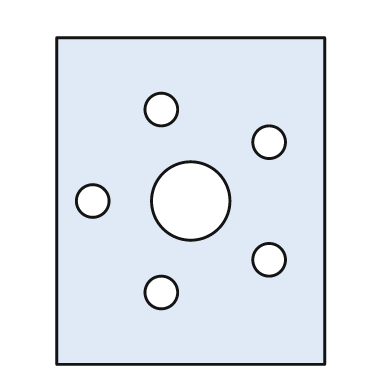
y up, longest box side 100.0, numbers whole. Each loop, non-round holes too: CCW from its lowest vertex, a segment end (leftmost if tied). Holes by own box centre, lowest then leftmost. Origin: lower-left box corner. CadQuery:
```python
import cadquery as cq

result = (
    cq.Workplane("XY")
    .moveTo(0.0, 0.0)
    .lineTo(82.0, 0.0)
    .lineTo(82.0, 100.0)
    .lineTo(0.0, 100.0)
    .close()
    .moveTo(32.0, 22.0)
    .circle(5.0)
    .moveTo(65.0, 32.0)
    .circle(5.0)
    .moveTo(11.0, 50.0)
    .circle(5.0)
    .moveTo(41.0, 50.0)
    .circle(12.0)
    .moveTo(65.0, 68.0)
    .circle(5.0)
    .moveTo(32.0, 78.0)
    .circle(5.0)
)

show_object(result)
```